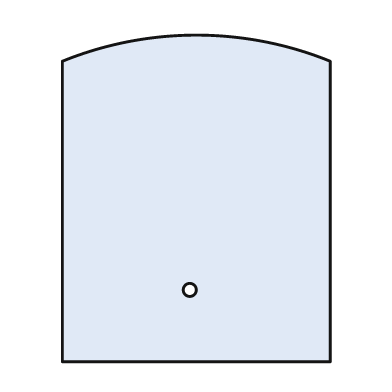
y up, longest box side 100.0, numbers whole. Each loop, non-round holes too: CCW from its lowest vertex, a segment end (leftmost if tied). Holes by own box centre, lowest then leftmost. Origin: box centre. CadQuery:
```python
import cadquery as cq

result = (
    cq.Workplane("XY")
    .moveTo(-41.0, -50.0)
    .lineTo(41.0, -50.0)
    .lineTo(41.0, 42.0)
    .threePointArc((0.0, 50.0), (-41.0, 42.0))
    .close()
    .moveTo(-2.0, -28.0)
    .circle(2.0)
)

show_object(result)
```